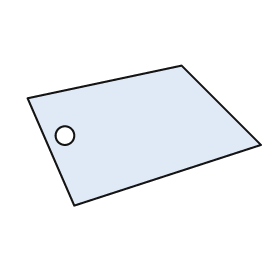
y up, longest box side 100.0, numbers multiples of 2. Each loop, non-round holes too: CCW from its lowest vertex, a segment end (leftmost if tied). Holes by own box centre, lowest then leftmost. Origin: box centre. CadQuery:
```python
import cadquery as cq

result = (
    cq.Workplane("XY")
    .moveTo(-30.0, -30.0)
    .lineTo(50.0, -4.0)
    .lineTo(16.0, 30.0)
    .lineTo(-50.0, 16.0)
    .close()
    .moveTo(-34.0, 0.0)
    .circle(4.0)
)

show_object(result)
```